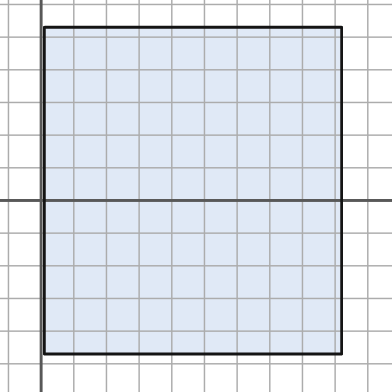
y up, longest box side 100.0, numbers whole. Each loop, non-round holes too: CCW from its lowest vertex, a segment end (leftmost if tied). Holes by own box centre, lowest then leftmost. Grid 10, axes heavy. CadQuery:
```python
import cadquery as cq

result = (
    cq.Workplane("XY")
    .moveTo(1.0, -47.0)
    .lineTo(92.0, -47.0)
    .lineTo(92.0, 53.0)
    .lineTo(1.0, 53.0)
    .close()
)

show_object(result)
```